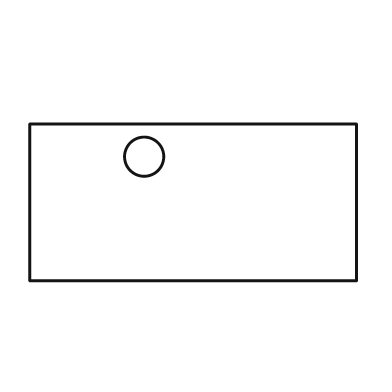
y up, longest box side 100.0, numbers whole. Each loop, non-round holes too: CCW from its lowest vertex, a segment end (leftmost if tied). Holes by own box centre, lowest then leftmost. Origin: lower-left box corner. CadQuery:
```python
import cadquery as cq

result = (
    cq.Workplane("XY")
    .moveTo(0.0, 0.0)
    .lineTo(100.0, 0.0)
    .lineTo(100.0, 48.0)
    .lineTo(0.0, 48.0)
    .close()
    .moveTo(35.0, 38.0)
    .circle(6.0)
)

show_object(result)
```